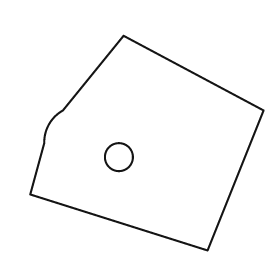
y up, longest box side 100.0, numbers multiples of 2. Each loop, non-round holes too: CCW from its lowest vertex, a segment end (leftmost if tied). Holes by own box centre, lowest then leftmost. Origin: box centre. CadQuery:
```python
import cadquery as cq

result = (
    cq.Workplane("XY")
    .moveTo(26.0, -46.0)
    .lineTo(50.0, 14.0)
    .lineTo(-10.0, 46.0)
    .lineTo(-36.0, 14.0)
    .threePointArc((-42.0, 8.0), (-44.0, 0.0))
    .lineTo(-50.0, -22.0)
    .close()
    .moveTo(-12.0, -6.0)
    .circle(6.0)
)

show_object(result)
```